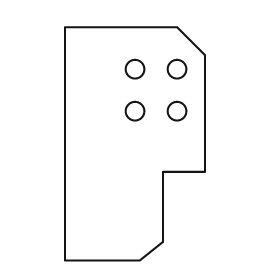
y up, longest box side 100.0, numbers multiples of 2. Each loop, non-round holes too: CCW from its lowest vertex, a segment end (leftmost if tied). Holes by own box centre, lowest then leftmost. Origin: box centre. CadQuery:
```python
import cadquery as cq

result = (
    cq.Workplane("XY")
    .moveTo(-30.0, -50.0)
    .lineTo(2.0, -50.0)
    .lineTo(12.0, -42.0)
    .lineTo(12.0, -12.0)
    .lineTo(30.0, -12.0)
    .lineTo(30.0, 38.0)
    .lineTo(18.0, 50.0)
    .lineTo(-30.0, 50.0)
    .close()
    .moveTo(0.0, 14.0)
    .circle(4.0)
    .moveTo(18.0, 14.0)
    .circle(4.0)
    .moveTo(0.0, 32.0)
    .circle(4.0)
    .moveTo(18.0, 32.0)
    .circle(4.0)
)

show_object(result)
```